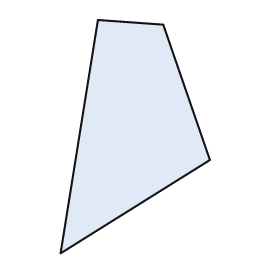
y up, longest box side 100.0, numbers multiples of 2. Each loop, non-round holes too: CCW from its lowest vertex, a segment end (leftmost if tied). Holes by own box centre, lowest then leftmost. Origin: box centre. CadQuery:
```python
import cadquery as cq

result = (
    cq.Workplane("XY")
    .moveTo(-32.0, -50.0)
    .lineTo(32.0, -10.0)
    .lineTo(12.0, 48.0)
    .lineTo(-16.0, 50.0)
    .close()
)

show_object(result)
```